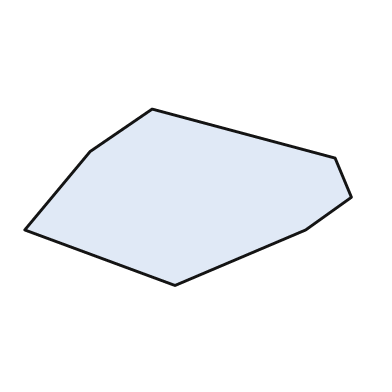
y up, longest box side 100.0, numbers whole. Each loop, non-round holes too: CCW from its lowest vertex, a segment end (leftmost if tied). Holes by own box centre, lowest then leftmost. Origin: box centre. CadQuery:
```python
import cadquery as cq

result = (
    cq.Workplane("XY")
    .moveTo(-4.0, -27.0)
    .lineTo(36.0, -10.0)
    .lineTo(50.0, 0.0)
    .lineTo(45.0, 12.0)
    .lineTo(-11.0, 27.0)
    .lineTo(-30.0, 14.0)
    .lineTo(-50.0, -10.0)
    .close()
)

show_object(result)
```